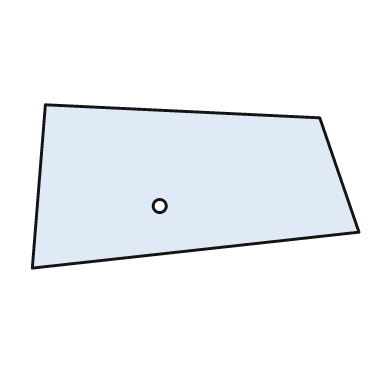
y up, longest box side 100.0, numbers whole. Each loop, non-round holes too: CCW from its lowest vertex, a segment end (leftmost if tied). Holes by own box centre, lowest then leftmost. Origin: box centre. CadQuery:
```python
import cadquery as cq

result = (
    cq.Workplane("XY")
    .moveTo(-50.0, -25.0)
    .lineTo(50.0, -14.0)
    .lineTo(38.0, 21.0)
    .lineTo(-46.0, 25.0)
    .close()
    .moveTo(-11.0, -6.0)
    .circle(2.0)
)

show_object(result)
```